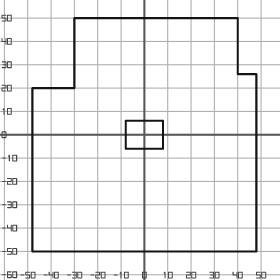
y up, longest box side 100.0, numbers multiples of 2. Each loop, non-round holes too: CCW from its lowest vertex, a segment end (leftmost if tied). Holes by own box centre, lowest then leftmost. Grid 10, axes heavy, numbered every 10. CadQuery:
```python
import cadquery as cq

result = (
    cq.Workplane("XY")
    .moveTo(-48.0, -50.0)
    .lineTo(48.0, -50.0)
    .lineTo(48.0, 26.0)
    .lineTo(40.0, 26.0)
    .lineTo(40.0, 50.0)
    .lineTo(-30.0, 50.0)
    .lineTo(-30.0, 20.0)
    .lineTo(-48.0, 20.0)
    .close()
    .moveTo(-8.0, -6.0)
    .lineTo(8.0, -6.0)
    .lineTo(8.0, 6.0)
    .lineTo(-8.0, 6.0)
    .close()
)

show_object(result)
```